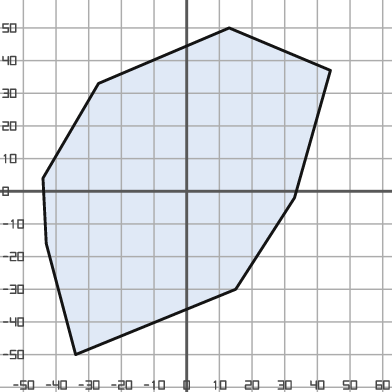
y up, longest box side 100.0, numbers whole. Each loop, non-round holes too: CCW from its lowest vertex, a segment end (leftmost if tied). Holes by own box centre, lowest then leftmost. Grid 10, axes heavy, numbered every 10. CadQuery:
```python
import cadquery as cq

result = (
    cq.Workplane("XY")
    .moveTo(-34.0, -50.0)
    .lineTo(15.0, -30.0)
    .lineTo(33.0, -2.0)
    .lineTo(44.0, 37.0)
    .lineTo(13.0, 50.0)
    .lineTo(-27.0, 33.0)
    .lineTo(-44.0, 4.0)
    .lineTo(-43.0, -16.0)
    .close()
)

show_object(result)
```